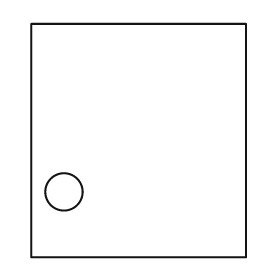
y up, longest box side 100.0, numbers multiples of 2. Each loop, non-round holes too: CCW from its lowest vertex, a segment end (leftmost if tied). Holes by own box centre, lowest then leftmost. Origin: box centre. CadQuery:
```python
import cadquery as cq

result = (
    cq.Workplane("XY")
    .moveTo(-46.0, -50.0)
    .lineTo(46.0, -50.0)
    .lineTo(46.0, 50.0)
    .lineTo(-46.0, 50.0)
    .close()
    .moveTo(-32.0, -22.0)
    .circle(8.0)
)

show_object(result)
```